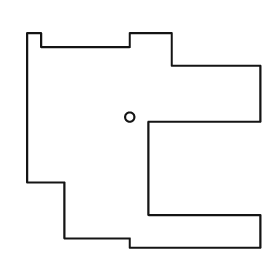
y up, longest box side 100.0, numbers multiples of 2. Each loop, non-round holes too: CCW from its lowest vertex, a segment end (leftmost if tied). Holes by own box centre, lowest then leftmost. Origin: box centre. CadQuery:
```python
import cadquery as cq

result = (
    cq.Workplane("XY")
    .moveTo(-6.0, -46.0)
    .lineTo(50.0, -46.0)
    .lineTo(50.0, -32.0)
    .lineTo(2.0, -32.0)
    .lineTo(2.0, 8.0)
    .lineTo(50.0, 8.0)
    .lineTo(50.0, 32.0)
    .lineTo(12.0, 32.0)
    .lineTo(12.0, 46.0)
    .lineTo(-6.0, 46.0)
    .lineTo(-6.0, 40.0)
    .lineTo(-44.0, 40.0)
    .lineTo(-44.0, 46.0)
    .lineTo(-50.0, 46.0)
    .lineTo(-50.0, -18.0)
    .lineTo(-34.0, -18.0)
    .lineTo(-34.0, -42.0)
    .lineTo(-6.0, -42.0)
    .close()
    .moveTo(-6.0, 10.0)
    .circle(2.0)
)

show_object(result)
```